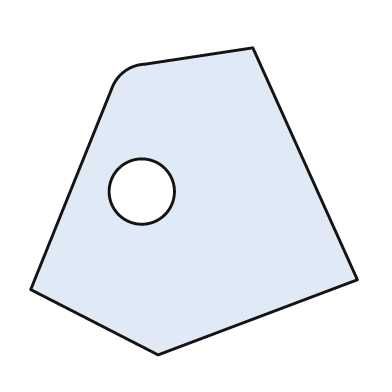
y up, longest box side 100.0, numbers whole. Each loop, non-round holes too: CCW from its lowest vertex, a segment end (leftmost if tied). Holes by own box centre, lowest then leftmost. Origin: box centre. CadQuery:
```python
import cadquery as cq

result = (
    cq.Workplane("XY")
    .moveTo(-11.0, -47.0)
    .lineTo(50.0, -24.0)
    .lineTo(18.0, 47.0)
    .lineTo(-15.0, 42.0)
    .threePointArc((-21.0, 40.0), (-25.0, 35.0))
    .lineTo(-50.0, -27.0)
    .close()
    .moveTo(-16.0, 3.0)
    .circle(10.0)
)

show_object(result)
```